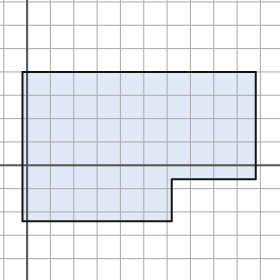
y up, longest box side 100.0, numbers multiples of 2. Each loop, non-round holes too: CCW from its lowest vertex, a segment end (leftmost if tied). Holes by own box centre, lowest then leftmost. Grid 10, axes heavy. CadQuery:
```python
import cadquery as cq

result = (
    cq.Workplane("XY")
    .moveTo(-2.0, -24.0)
    .lineTo(62.0, -24.0)
    .lineTo(62.0, -6.0)
    .lineTo(98.0, -6.0)
    .lineTo(98.0, 40.0)
    .lineTo(-2.0, 40.0)
    .close()
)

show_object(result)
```